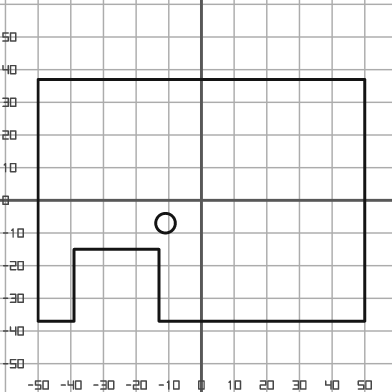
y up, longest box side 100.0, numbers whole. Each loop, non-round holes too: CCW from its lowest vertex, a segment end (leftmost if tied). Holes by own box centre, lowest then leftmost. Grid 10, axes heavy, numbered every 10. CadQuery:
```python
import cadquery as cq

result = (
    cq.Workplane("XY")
    .moveTo(-50.0, -37.0)
    .lineTo(-39.0, -37.0)
    .lineTo(-39.0, -15.0)
    .lineTo(-13.0, -15.0)
    .lineTo(-13.0, -37.0)
    .lineTo(50.0, -37.0)
    .lineTo(50.0, 37.0)
    .lineTo(-50.0, 37.0)
    .close()
    .moveTo(-11.0, -7.0)
    .circle(3.0)
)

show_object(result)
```